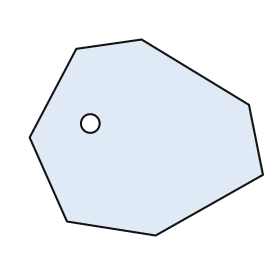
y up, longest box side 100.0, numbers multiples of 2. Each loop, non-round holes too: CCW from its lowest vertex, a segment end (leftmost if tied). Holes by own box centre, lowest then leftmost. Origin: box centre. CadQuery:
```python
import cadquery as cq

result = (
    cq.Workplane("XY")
    .moveTo(4.0, -42.0)
    .lineTo(50.0, -16.0)
    .lineTo(44.0, 14.0)
    .lineTo(-2.0, 42.0)
    .lineTo(-30.0, 38.0)
    .lineTo(-50.0, 0.0)
    .lineTo(-34.0, -36.0)
    .close()
    .moveTo(-24.0, 6.0)
    .circle(4.0)
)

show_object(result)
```